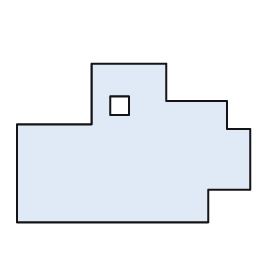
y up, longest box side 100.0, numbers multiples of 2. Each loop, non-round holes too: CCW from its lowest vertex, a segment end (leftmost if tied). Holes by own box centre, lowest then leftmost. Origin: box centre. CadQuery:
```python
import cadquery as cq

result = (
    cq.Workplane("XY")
    .moveTo(-50.0, -34.0)
    .lineTo(32.0, -34.0)
    .lineTo(32.0, -20.0)
    .lineTo(50.0, -20.0)
    .lineTo(50.0, 6.0)
    .lineTo(40.0, 6.0)
    .lineTo(40.0, 18.0)
    .lineTo(14.0, 18.0)
    .lineTo(14.0, 34.0)
    .lineTo(-18.0, 34.0)
    .lineTo(-18.0, 8.0)
    .lineTo(-50.0, 8.0)
    .close()
    .moveTo(-10.0, 12.0)
    .lineTo(-2.0, 12.0)
    .lineTo(-2.0, 20.0)
    .lineTo(-10.0, 20.0)
    .close()
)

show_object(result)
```